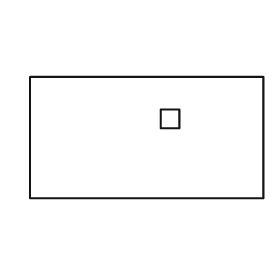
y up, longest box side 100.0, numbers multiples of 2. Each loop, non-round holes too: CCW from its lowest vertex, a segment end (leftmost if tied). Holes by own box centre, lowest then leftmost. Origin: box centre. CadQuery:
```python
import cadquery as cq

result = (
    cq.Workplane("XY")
    .moveTo(-50.0, -26.0)
    .lineTo(50.0, -26.0)
    .lineTo(50.0, 26.0)
    .lineTo(-50.0, 26.0)
    .close()
    .moveTo(6.0, 4.0)
    .lineTo(14.0, 4.0)
    .lineTo(14.0, 12.0)
    .lineTo(6.0, 12.0)
    .close()
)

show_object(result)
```